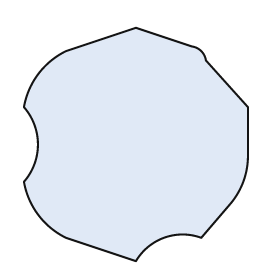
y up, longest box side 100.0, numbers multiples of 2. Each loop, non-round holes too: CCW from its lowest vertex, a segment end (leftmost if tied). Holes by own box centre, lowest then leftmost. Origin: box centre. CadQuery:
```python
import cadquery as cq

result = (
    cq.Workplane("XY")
    .moveTo(0.0, -50.0)
    .threePointArc((12.0, -40.0), (28.0, -40.0))
    .lineTo(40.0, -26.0)
    .threePointArc((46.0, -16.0), (48.0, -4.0))
    .lineTo(48.0, 16.0)
    .lineTo(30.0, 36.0)
    .threePointArc((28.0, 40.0), (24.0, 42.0))
    .lineTo(0.0, 50.0)
    .lineTo(-30.0, 40.0)
    .threePointArc((-42.0, 30.0), (-48.0, 16.0))
    .threePointArc((-42.0, 0.0), (-48.0, -16.0))
    .threePointArc((-42.0, -30.0), (-30.0, -40.0))
    .close()
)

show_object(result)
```